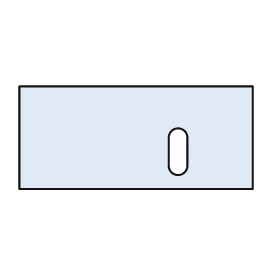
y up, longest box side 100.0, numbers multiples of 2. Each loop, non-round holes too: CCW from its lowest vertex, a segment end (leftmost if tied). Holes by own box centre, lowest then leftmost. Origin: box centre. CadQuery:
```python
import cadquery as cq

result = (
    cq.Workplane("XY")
    .moveTo(-50.0, -22.0)
    .lineTo(50.0, -22.0)
    .lineTo(50.0, 22.0)
    .lineTo(-50.0, 22.0)
    .close()
    .moveTo(14.0, -12.0)
    .threePointArc((18.0, -16.0), (22.0, -12.0))
    .lineTo(22.0, 0.0)
    .threePointArc((18.0, 4.0), (14.0, 0.0))
    .close()
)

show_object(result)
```